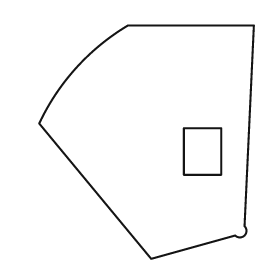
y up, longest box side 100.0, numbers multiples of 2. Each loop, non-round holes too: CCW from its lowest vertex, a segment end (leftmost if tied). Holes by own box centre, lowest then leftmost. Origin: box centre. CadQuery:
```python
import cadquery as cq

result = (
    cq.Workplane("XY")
    .moveTo(2.0, -50.0)
    .lineTo(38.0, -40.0)
    .threePointArc((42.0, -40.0), (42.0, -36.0))
    .lineTo(46.0, 50.0)
    .lineTo(-8.0, 50.0)
    .threePointArc((-30.0, 32.0), (-46.0, 8.0))
    .close()
    .moveTo(16.0, -14.0)
    .lineTo(32.0, -14.0)
    .lineTo(32.0, 6.0)
    .lineTo(16.0, 6.0)
    .close()
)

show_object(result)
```